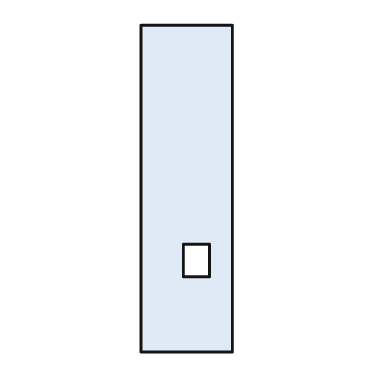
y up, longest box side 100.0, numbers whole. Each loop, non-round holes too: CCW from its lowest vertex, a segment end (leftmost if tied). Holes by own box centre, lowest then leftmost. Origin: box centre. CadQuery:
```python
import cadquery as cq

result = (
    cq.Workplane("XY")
    .moveTo(-14.0, -50.0)
    .lineTo(14.0, -50.0)
    .lineTo(14.0, 50.0)
    .lineTo(-14.0, 50.0)
    .close()
    .moveTo(-1.0, -27.0)
    .lineTo(7.0, -27.0)
    .lineTo(7.0, -17.0)
    .lineTo(-1.0, -17.0)
    .close()
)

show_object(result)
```